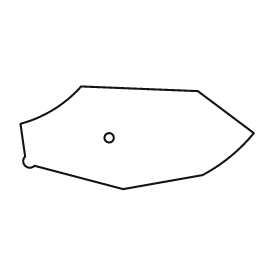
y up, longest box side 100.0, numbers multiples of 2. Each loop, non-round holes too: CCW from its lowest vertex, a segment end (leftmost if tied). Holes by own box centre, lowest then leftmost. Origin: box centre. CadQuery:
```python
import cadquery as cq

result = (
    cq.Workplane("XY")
    .moveTo(-6.0, -22.0)
    .lineTo(28.0, -16.0)
    .threePointArc((40.0, -8.0), (50.0, 2.0))
    .lineTo(26.0, 20.0)
    .lineTo(-24.0, 22.0)
    .threePointArc((-36.0, 12.0), (-50.0, 6.0))
    .lineTo(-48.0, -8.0)
    .threePointArc((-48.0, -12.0), (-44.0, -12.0))
    .close()
    .moveTo(-12.0, 0.0)
    .circle(2.0)
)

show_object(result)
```